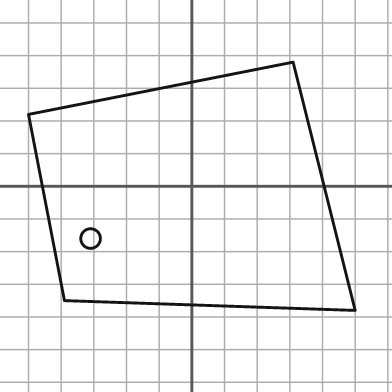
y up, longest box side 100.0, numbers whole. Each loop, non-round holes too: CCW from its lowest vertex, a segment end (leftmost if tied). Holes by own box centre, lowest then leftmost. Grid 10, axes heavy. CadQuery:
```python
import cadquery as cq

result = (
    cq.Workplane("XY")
    .moveTo(50.0, -38.0)
    .lineTo(31.0, 38.0)
    .lineTo(-50.0, 22.0)
    .lineTo(-39.0, -35.0)
    .close()
    .moveTo(-31.0, -16.0)
    .circle(3.0)
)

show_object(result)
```